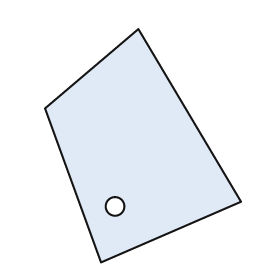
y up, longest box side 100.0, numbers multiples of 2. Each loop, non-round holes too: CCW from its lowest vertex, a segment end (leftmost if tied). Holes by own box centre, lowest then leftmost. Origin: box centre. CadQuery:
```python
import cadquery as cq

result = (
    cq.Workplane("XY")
    .moveTo(-18.0, -50.0)
    .lineTo(42.0, -24.0)
    .lineTo(-2.0, 50.0)
    .lineTo(-42.0, 16.0)
    .close()
    .moveTo(-12.0, -26.0)
    .circle(4.0)
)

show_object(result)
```